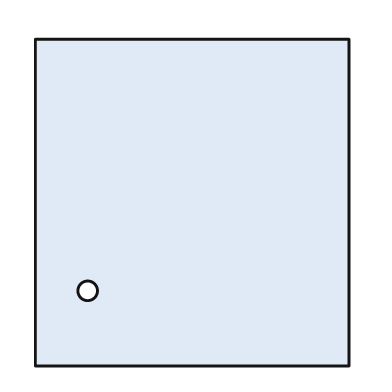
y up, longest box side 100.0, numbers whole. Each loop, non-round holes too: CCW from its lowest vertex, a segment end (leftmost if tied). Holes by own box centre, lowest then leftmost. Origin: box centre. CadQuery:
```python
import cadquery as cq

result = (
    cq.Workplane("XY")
    .moveTo(-48.0, -50.0)
    .lineTo(48.0, -50.0)
    .lineTo(48.0, 50.0)
    .lineTo(-48.0, 50.0)
    .close()
    .moveTo(-32.0, -27.0)
    .circle(3.0)
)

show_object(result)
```